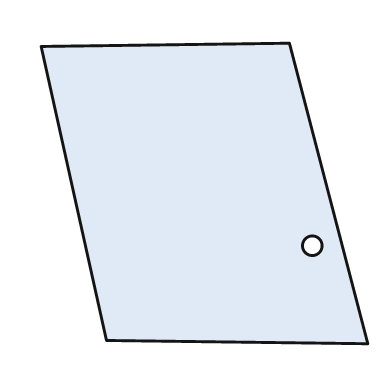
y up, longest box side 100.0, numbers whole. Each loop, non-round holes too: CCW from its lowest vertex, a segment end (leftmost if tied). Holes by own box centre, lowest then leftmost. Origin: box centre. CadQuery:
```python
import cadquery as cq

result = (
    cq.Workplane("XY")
    .moveTo(50.0, -46.0)
    .lineTo(26.0, 46.0)
    .lineTo(-50.0, 45.0)
    .lineTo(-30.0, -45.0)
    .close()
    .moveTo(33.0, -16.0)
    .circle(3.0)
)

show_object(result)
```